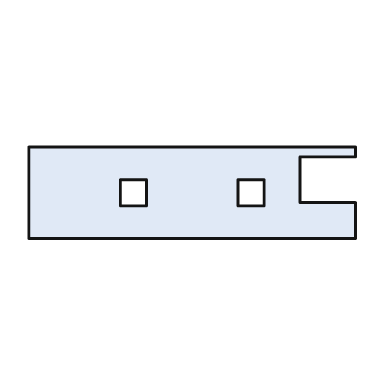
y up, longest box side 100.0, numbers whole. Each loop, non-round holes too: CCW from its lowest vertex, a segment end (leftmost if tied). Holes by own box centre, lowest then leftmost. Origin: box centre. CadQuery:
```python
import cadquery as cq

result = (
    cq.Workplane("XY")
    .moveTo(-50.0, -14.0)
    .lineTo(50.0, -14.0)
    .lineTo(50.0, -3.0)
    .lineTo(33.0, -3.0)
    .lineTo(33.0, 11.0)
    .lineTo(50.0, 11.0)
    .lineTo(50.0, 14.0)
    .lineTo(-50.0, 14.0)
    .close()
    .moveTo(-22.0, -4.0)
    .lineTo(-14.0, -4.0)
    .lineTo(-14.0, 4.0)
    .lineTo(-22.0, 4.0)
    .close()
    .moveTo(14.0, -4.0)
    .lineTo(22.0, -4.0)
    .lineTo(22.0, 4.0)
    .lineTo(14.0, 4.0)
    .close()
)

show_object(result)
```